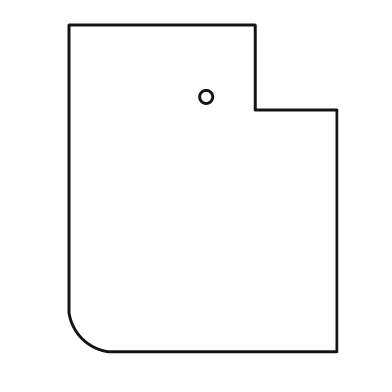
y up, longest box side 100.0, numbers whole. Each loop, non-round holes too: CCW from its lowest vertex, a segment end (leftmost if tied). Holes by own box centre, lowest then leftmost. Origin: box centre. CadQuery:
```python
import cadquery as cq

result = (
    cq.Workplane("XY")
    .moveTo(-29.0, -50.0)
    .lineTo(41.0, -50.0)
    .lineTo(41.0, 24.0)
    .lineTo(16.0, 24.0)
    .lineTo(16.0, 50.0)
    .lineTo(-41.0, 50.0)
    .lineTo(-41.0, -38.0)
    .threePointArc((-37.0, -46.0), (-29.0, -50.0))
    .close()
    .moveTo(1.0, 28.0)
    .circle(2.0)
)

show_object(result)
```